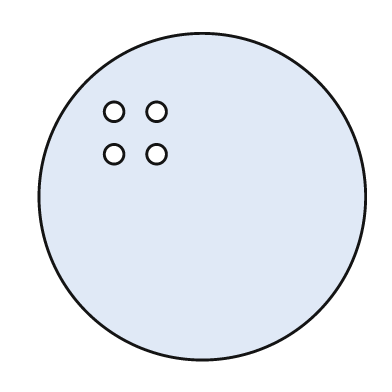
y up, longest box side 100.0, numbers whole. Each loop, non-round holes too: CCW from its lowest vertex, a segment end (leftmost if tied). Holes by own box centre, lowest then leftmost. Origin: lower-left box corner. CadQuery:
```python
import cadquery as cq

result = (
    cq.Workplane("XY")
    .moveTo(50.0, 50.0)
    .circle(50.0)
    .moveTo(23.0, 63.0)
    .circle(3.0)
    .moveTo(36.0, 63.0)
    .circle(3.0)
    .moveTo(23.0, 76.0)
    .circle(3.0)
    .moveTo(36.0, 76.0)
    .circle(3.0)
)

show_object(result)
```